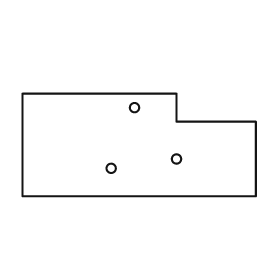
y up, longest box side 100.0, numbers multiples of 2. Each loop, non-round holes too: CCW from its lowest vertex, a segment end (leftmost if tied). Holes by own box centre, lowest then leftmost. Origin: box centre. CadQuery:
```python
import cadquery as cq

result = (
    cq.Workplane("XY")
    .moveTo(-50.0, -22.0)
    .lineTo(50.0, -22.0)
    .lineTo(50.0, 10.0)
    .lineTo(16.0, 10.0)
    .lineTo(16.0, 22.0)
    .lineTo(-50.0, 22.0)
    .close()
    .moveTo(-12.0, -10.0)
    .circle(2.0)
    .moveTo(16.0, -6.0)
    .circle(2.0)
    .moveTo(-2.0, 16.0)
    .circle(2.0)
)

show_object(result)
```